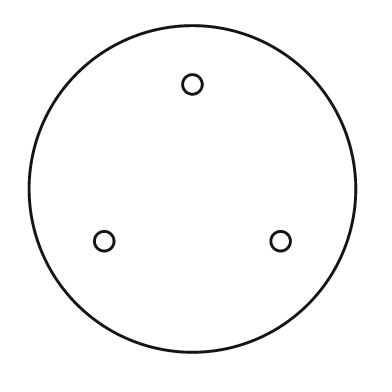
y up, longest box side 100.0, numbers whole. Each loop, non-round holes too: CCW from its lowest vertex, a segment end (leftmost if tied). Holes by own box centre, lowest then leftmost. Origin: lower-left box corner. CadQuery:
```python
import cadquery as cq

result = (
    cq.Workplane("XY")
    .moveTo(50.0, 50.0)
    .circle(50.0)
    .moveTo(23.0, 34.0)
    .circle(3.0)
    .moveTo(77.0, 34.0)
    .circle(3.0)
    .moveTo(50.0, 82.0)
    .circle(3.0)
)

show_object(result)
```